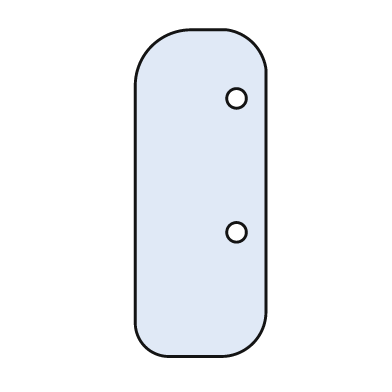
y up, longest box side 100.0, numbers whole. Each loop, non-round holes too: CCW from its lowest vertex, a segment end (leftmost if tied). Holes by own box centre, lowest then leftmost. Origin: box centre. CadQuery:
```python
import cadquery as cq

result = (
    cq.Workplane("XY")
    .moveTo(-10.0, -50.0)
    .lineTo(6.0, -50.0)
    .threePointArc((16.0, -46.0), (20.0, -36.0))
    .lineTo(20.0, 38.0)
    .threePointArc((16.0, 46.0), (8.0, 50.0))
    .lineTo(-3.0, 50.0)
    .threePointArc((-15.0, 45.0), (-20.0, 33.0))
    .lineTo(-20.0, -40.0)
    .threePointArc((-17.0, -47.0), (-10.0, -50.0))
    .close()
    .moveTo(11.0, -12.0)
    .circle(3.0)
    .moveTo(11.0, 29.0)
    .circle(3.0)
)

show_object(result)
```